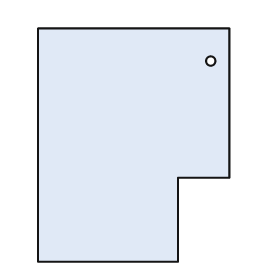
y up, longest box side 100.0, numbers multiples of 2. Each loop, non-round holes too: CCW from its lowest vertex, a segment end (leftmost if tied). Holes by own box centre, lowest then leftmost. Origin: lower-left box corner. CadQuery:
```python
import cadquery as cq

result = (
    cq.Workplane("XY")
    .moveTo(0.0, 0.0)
    .lineTo(60.0, 0.0)
    .lineTo(60.0, 36.0)
    .lineTo(82.0, 36.0)
    .lineTo(82.0, 100.0)
    .lineTo(0.0, 100.0)
    .close()
    .moveTo(74.0, 86.0)
    .circle(2.0)
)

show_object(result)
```